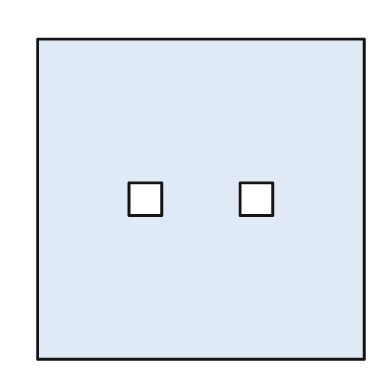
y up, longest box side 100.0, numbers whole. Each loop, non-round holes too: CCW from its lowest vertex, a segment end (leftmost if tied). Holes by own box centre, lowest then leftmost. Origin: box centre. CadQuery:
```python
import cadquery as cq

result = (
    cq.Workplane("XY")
    .moveTo(-50.0, -49.0)
    .lineTo(50.0, -49.0)
    .lineTo(50.0, 49.0)
    .lineTo(-50.0, 49.0)
    .close()
    .moveTo(-22.0, -5.0)
    .lineTo(-12.0, -5.0)
    .lineTo(-12.0, 5.0)
    .lineTo(-22.0, 5.0)
    .close()
    .moveTo(12.0, -5.0)
    .lineTo(22.0, -5.0)
    .lineTo(22.0, 5.0)
    .lineTo(12.0, 5.0)
    .close()
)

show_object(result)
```